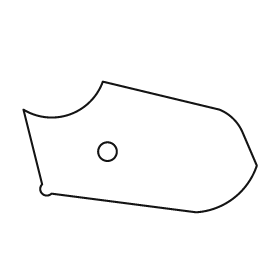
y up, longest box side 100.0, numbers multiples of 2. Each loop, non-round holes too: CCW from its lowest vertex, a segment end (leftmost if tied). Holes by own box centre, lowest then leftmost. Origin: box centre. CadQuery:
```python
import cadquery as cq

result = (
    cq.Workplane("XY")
    .moveTo(24.0, -28.0)
    .threePointArc((40.0, -22.0), (50.0, -8.0))
    .lineTo(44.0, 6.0)
    .threePointArc((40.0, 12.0), (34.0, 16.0))
    .lineTo(-16.0, 28.0)
    .threePointArc((-30.0, 14.0), (-50.0, 16.0))
    .lineTo(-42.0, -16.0)
    .threePointArc((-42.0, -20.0), (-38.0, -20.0))
    .close()
    .moveTo(-14.0, -2.0)
    .circle(4.0)
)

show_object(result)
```